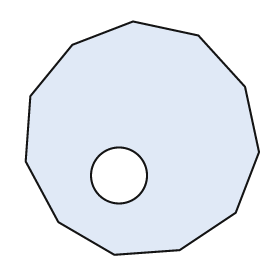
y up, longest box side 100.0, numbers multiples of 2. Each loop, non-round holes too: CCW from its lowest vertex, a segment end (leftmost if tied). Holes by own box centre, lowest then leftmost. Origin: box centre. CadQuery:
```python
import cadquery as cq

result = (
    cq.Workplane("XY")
    .moveTo(-12.0, -50.0)
    .lineTo(16.0, -48.0)
    .lineTo(40.0, -32.0)
    .lineTo(50.0, -6.0)
    .lineTo(44.0, 22.0)
    .lineTo(24.0, 44.0)
    .lineTo(-4.0, 50.0)
    .lineTo(-30.0, 40.0)
    .lineTo(-48.0, 18.0)
    .lineTo(-50.0, -10.0)
    .lineTo(-36.0, -36.0)
    .close()
    .moveTo(-10.0, -16.0)
    .circle(12.0)
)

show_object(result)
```